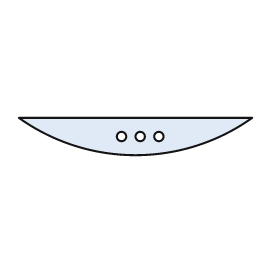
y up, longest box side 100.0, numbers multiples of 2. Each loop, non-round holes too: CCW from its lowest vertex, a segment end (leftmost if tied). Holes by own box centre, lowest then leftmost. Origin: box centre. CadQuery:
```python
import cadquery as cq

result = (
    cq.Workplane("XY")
    .moveTo(-50.0, 8.0)
    .threePointArc((0.0, -8.0), (50.0, 8.0))
    .close()
    .moveTo(-6.0, 0.0)
    .circle(2.0)
    .moveTo(2.0, 0.0)
    .circle(2.0)
    .moveTo(10.0, 0.0)
    .circle(2.0)
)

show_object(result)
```